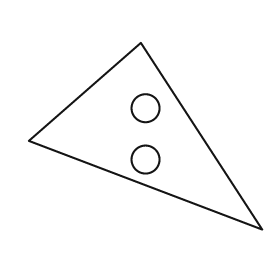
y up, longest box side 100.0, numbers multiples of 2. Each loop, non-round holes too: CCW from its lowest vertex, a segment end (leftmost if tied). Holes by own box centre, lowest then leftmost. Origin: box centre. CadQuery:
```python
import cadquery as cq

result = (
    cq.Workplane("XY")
    .moveTo(50.0, -40.0)
    .lineTo(-2.0, 40.0)
    .lineTo(-50.0, -2.0)
    .close()
    .moveTo(0.0, -10.0)
    .circle(6.0)
    .moveTo(0.0, 12.0)
    .circle(6.0)
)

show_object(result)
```